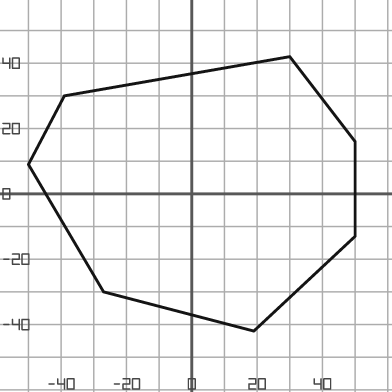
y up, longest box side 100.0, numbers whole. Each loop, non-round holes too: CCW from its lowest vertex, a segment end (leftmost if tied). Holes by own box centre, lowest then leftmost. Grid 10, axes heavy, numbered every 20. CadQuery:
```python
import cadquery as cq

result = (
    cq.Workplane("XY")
    .moveTo(19.0, -42.0)
    .lineTo(50.0, -13.0)
    .lineTo(50.0, 16.0)
    .lineTo(30.0, 42.0)
    .lineTo(-39.0, 30.0)
    .lineTo(-50.0, 9.0)
    .lineTo(-27.0, -30.0)
    .close()
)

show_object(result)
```